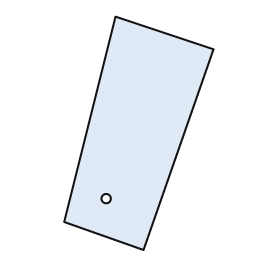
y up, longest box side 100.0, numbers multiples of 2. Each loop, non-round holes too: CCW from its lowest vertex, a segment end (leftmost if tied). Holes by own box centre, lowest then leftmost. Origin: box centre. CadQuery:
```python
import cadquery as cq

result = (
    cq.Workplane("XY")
    .moveTo(2.0, -50.0)
    .lineTo(32.0, 36.0)
    .lineTo(-10.0, 50.0)
    .lineTo(-32.0, -38.0)
    .close()
    .moveTo(-14.0, -28.0)
    .circle(2.0)
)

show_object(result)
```